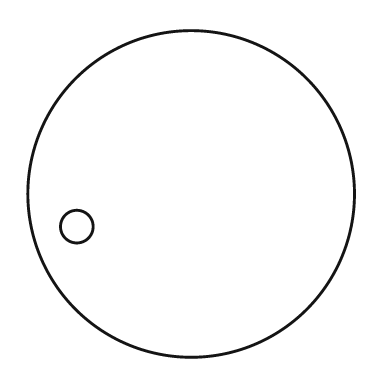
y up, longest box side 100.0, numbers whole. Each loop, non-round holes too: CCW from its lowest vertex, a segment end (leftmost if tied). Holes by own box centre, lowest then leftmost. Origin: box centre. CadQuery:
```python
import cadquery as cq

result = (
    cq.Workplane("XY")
    .moveTo(0.0, 0.0)
    .circle(50.0)
    .moveTo(-35.0, -10.0)
    .circle(5.0)
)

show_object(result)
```